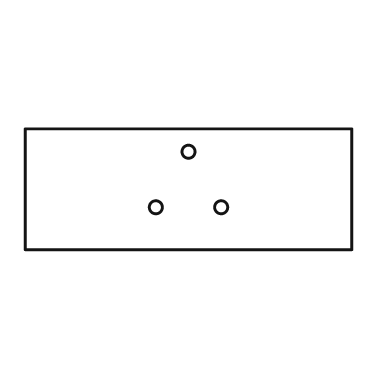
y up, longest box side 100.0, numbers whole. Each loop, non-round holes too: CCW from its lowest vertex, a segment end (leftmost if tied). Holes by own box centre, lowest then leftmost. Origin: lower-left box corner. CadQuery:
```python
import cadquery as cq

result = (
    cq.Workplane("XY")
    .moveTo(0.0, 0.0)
    .lineTo(100.0, 0.0)
    .lineTo(100.0, 37.0)
    .lineTo(0.0, 37.0)
    .close()
    .moveTo(40.0, 13.0)
    .circle(2.0)
    .moveTo(60.0, 13.0)
    .circle(2.0)
    .moveTo(50.0, 30.0)
    .circle(2.0)
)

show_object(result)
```